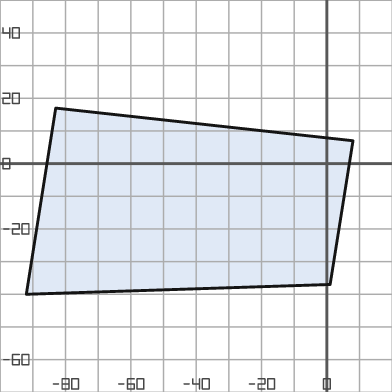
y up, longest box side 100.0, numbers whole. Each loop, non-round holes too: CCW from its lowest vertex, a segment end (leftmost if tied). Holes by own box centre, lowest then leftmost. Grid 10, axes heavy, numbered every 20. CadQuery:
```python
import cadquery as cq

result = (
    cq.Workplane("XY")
    .moveTo(-92.0, -40.0)
    .lineTo(1.0, -37.0)
    .lineTo(8.0, 7.0)
    .lineTo(-83.0, 17.0)
    .close()
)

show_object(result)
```